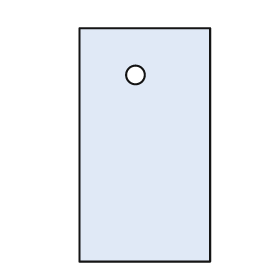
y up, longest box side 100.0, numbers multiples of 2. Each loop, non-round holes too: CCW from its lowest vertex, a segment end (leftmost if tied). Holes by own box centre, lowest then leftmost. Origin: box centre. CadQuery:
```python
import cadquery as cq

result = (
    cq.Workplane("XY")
    .moveTo(-28.0, -50.0)
    .lineTo(28.0, -50.0)
    .lineTo(28.0, 50.0)
    .lineTo(-28.0, 50.0)
    .close()
    .moveTo(-4.0, 30.0)
    .circle(4.0)
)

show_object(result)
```